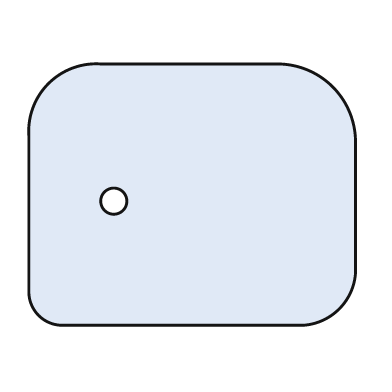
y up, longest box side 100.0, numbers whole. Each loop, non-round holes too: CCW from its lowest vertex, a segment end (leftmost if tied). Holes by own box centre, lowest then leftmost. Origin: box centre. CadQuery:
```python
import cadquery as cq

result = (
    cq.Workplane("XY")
    .moveTo(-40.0, -40.0)
    .lineTo(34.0, -40.0)
    .threePointArc((45.0, -35.0), (50.0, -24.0))
    .lineTo(50.0, 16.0)
    .threePointArc((43.0, 33.0), (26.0, 40.0))
    .lineTo(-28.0, 40.0)
    .threePointArc((-44.0, 34.0), (-50.0, 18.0))
    .lineTo(-50.0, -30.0)
    .threePointArc((-47.0, -37.0), (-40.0, -40.0))
    .close()
    .moveTo(-24.0, -2.0)
    .circle(4.0)
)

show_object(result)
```